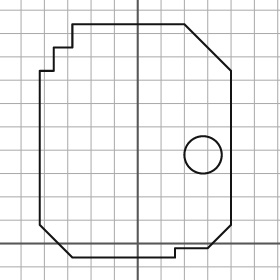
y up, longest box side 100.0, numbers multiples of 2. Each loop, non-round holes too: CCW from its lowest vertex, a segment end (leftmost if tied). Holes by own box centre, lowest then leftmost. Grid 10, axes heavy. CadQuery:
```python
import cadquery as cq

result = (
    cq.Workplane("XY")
    .moveTo(-28.0, -6.0)
    .lineTo(16.0, -6.0)
    .lineTo(16.0, -2.0)
    .lineTo(30.0, -2.0)
    .lineTo(40.0, 8.0)
    .lineTo(40.0, 74.0)
    .lineTo(20.0, 94.0)
    .lineTo(-28.0, 94.0)
    .lineTo(-28.0, 84.0)
    .lineTo(-36.0, 84.0)
    .lineTo(-36.0, 74.0)
    .lineTo(-42.0, 74.0)
    .lineTo(-42.0, 8.0)
    .close()
    .moveTo(28.0, 38.0)
    .circle(8.0)
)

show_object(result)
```